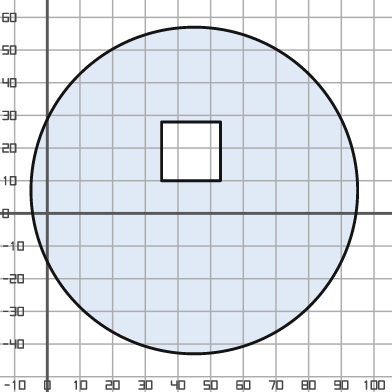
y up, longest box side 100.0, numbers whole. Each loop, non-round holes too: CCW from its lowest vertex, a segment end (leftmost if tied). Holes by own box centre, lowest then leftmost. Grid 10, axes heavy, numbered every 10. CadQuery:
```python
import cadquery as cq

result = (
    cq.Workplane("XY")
    .moveTo(45.0, 7.0)
    .circle(50.0)
    .moveTo(35.0, 10.0)
    .lineTo(53.0, 10.0)
    .lineTo(53.0, 28.0)
    .lineTo(35.0, 28.0)
    .close()
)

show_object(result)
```